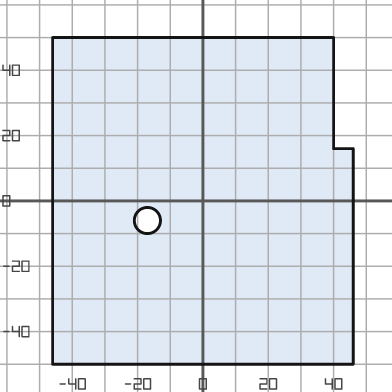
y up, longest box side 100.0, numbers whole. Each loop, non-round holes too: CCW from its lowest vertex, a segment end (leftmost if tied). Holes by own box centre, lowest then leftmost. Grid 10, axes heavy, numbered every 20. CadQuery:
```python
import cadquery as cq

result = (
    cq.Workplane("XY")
    .moveTo(-46.0, -50.0)
    .lineTo(46.0, -50.0)
    .lineTo(46.0, 16.0)
    .lineTo(40.0, 16.0)
    .lineTo(40.0, 50.0)
    .lineTo(-46.0, 50.0)
    .close()
    .moveTo(-17.0, -6.0)
    .circle(4.0)
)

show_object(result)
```